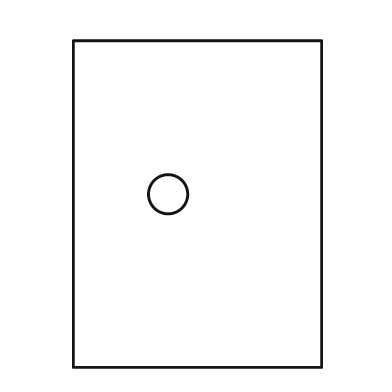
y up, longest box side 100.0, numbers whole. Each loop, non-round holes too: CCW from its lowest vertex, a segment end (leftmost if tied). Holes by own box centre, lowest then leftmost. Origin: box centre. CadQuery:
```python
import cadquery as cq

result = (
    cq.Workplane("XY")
    .moveTo(-38.0, -50.0)
    .lineTo(38.0, -50.0)
    .lineTo(38.0, 50.0)
    .lineTo(-38.0, 50.0)
    .close()
    .moveTo(-9.0, 3.0)
    .circle(6.0)
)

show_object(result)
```